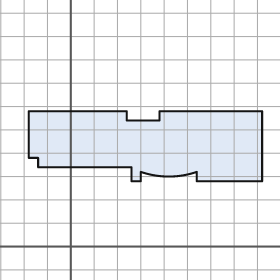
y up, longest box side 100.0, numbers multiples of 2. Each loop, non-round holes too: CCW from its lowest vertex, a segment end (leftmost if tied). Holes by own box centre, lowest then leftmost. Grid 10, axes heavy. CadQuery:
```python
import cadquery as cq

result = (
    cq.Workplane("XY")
    .moveTo(26.0, 28.0)
    .lineTo(30.0, 28.0)
    .lineTo(30.0, 32.0)
    .threePointArc((42.0, 30.0), (54.0, 32.0))
    .lineTo(54.0, 28.0)
    .lineTo(82.0, 28.0)
    .lineTo(82.0, 58.0)
    .lineTo(38.0, 58.0)
    .lineTo(38.0, 54.0)
    .lineTo(24.0, 54.0)
    .lineTo(24.0, 58.0)
    .lineTo(-18.0, 58.0)
    .lineTo(-18.0, 38.0)
    .lineTo(-14.0, 38.0)
    .lineTo(-14.0, 34.0)
    .lineTo(26.0, 34.0)
    .close()
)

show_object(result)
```